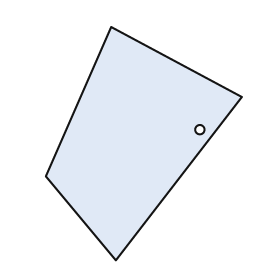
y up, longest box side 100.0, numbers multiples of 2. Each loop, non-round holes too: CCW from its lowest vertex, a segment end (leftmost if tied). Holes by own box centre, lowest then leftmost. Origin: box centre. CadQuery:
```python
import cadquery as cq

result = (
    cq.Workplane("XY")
    .moveTo(-12.0, -50.0)
    .lineTo(42.0, 20.0)
    .lineTo(-14.0, 50.0)
    .lineTo(-42.0, -14.0)
    .close()
    .moveTo(24.0, 6.0)
    .circle(2.0)
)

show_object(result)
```